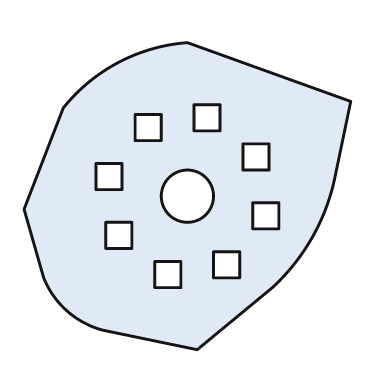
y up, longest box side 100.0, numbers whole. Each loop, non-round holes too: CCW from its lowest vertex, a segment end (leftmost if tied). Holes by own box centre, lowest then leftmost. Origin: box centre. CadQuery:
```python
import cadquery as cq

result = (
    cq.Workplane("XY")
    .moveTo(3.0, -47.0)
    .lineTo(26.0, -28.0)
    .threePointArc((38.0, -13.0), (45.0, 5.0))
    .lineTo(50.0, 29.0)
    .lineTo(0.0, 47.0)
    .threePointArc((-21.0, 41.0), (-38.0, 27.0))
    .lineTo(-50.0, -4.0)
    .lineTo(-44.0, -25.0)
    .threePointArc((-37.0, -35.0), (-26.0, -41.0))
    .close()
    .moveTo(-10.0, -28.0)
    .lineTo(-2.0, -28.0)
    .lineTo(-2.0, -20.0)
    .lineTo(-10.0, -20.0)
    .close()
    .moveTo(8.0, -25.0)
    .lineTo(16.0, -25.0)
    .lineTo(16.0, -17.0)
    .lineTo(8.0, -17.0)
    .close()
    .moveTo(-25.0, -16.0)
    .lineTo(-17.0, -16.0)
    .lineTo(-17.0, -8.0)
    .lineTo(-25.0, -8.0)
    .close()
    .moveTo(20.0, -10.0)
    .lineTo(28.0, -10.0)
    .lineTo(28.0, -2.0)
    .lineTo(20.0, -2.0)
    .close()
    .moveTo(0.0, 0.0)
    .circle(8.0)
    .moveTo(-28.0, 2.0)
    .lineTo(-20.0, 2.0)
    .lineTo(-20.0, 10.0)
    .lineTo(-28.0, 10.0)
    .close()
    .moveTo(17.0, 8.0)
    .lineTo(25.0, 8.0)
    .lineTo(25.0, 16.0)
    .lineTo(17.0, 16.0)
    .close()
    .moveTo(-16.0, 17.0)
    .lineTo(-8.0, 17.0)
    .lineTo(-8.0, 25.0)
    .lineTo(-16.0, 25.0)
    .close()
    .moveTo(2.0, 20.0)
    .lineTo(10.0, 20.0)
    .lineTo(10.0, 28.0)
    .lineTo(2.0, 28.0)
    .close()
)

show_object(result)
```